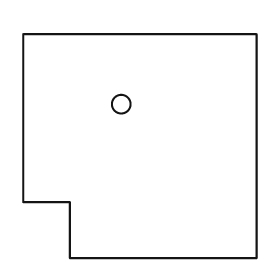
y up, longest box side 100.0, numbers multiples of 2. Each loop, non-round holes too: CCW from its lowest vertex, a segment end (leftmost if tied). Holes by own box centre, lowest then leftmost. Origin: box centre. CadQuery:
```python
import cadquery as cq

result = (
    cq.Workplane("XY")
    .moveTo(-30.0, -48.0)
    .lineTo(50.0, -48.0)
    .lineTo(50.0, 48.0)
    .lineTo(-50.0, 48.0)
    .lineTo(-50.0, -24.0)
    .lineTo(-30.0, -24.0)
    .close()
    .moveTo(-8.0, 18.0)
    .circle(4.0)
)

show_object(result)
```